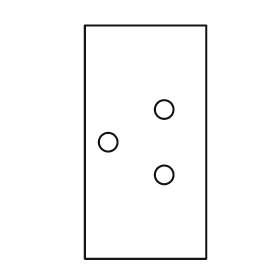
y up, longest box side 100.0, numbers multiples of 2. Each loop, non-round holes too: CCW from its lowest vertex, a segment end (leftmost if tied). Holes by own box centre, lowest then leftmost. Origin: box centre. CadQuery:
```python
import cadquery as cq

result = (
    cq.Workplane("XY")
    .moveTo(-26.0, -50.0)
    .lineTo(26.0, -50.0)
    .lineTo(26.0, 50.0)
    .lineTo(-26.0, 50.0)
    .close()
    .moveTo(8.0, -14.0)
    .circle(4.0)
    .moveTo(-16.0, 0.0)
    .circle(4.0)
    .moveTo(8.0, 14.0)
    .circle(4.0)
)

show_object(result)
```